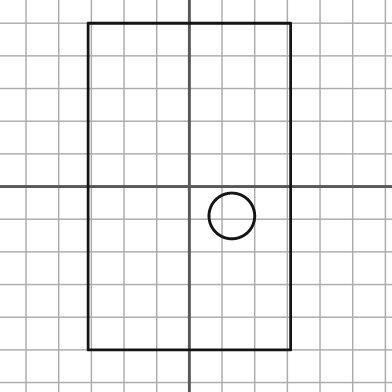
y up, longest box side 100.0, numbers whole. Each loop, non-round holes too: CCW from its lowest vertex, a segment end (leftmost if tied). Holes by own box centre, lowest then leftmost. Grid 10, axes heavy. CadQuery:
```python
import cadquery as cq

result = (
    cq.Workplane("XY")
    .moveTo(-31.0, -50.0)
    .lineTo(31.0, -50.0)
    .lineTo(31.0, 50.0)
    .lineTo(-31.0, 50.0)
    .close()
    .moveTo(13.0, -9.0)
    .circle(7.0)
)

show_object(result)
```